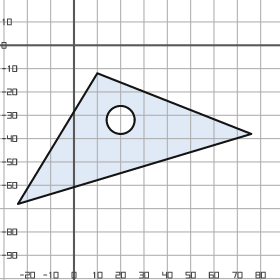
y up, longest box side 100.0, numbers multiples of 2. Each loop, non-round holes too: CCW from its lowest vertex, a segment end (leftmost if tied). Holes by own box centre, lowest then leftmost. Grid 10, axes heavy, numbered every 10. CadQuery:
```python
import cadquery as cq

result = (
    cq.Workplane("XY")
    .moveTo(-24.0, -68.0)
    .lineTo(76.0, -38.0)
    .lineTo(10.0, -12.0)
    .close()
    .moveTo(20.0, -32.0)
    .circle(6.0)
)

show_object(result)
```